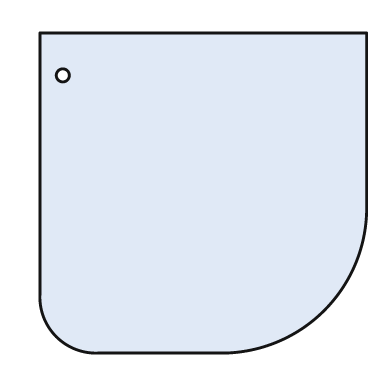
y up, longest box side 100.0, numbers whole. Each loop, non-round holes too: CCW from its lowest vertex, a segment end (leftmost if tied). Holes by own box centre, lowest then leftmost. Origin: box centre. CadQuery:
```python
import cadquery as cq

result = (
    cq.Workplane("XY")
    .moveTo(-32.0, -49.0)
    .lineTo(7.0, -49.0)
    .threePointArc((37.0, -36.0), (50.0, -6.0))
    .lineTo(50.0, 49.0)
    .lineTo(-50.0, 49.0)
    .lineTo(-50.0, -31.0)
    .threePointArc((-45.0, -44.0), (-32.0, -49.0))
    .close()
    .moveTo(-43.0, 36.0)
    .circle(2.0)
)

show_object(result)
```